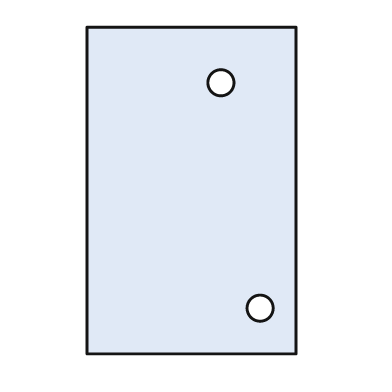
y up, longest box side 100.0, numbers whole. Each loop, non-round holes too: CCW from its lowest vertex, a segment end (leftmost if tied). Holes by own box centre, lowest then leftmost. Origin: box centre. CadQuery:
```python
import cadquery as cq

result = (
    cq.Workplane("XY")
    .moveTo(-32.0, -50.0)
    .lineTo(32.0, -50.0)
    .lineTo(32.0, 50.0)
    .lineTo(-32.0, 50.0)
    .close()
    .moveTo(21.0, -36.0)
    .circle(4.0)
    .moveTo(9.0, 33.0)
    .circle(4.0)
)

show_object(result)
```